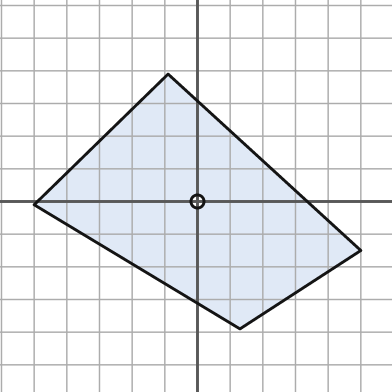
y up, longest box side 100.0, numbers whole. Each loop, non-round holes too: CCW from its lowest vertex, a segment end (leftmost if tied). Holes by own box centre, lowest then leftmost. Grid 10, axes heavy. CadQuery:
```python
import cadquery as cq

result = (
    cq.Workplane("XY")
    .moveTo(13.0, -39.0)
    .lineTo(50.0, -15.0)
    .lineTo(-9.0, 39.0)
    .lineTo(-50.0, -1.0)
    .close()
    .moveTo(0.0, 0.0)
    .circle(2.0)
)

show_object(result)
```